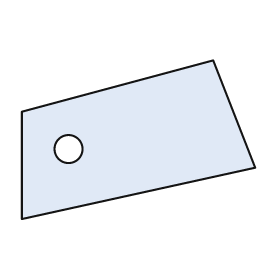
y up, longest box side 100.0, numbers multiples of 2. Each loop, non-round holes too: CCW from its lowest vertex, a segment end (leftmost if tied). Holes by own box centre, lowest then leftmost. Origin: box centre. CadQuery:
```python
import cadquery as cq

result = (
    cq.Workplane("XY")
    .moveTo(-50.0, -34.0)
    .lineTo(50.0, -12.0)
    .lineTo(32.0, 34.0)
    .lineTo(-50.0, 12.0)
    .close()
    .moveTo(-30.0, -4.0)
    .circle(6.0)
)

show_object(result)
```